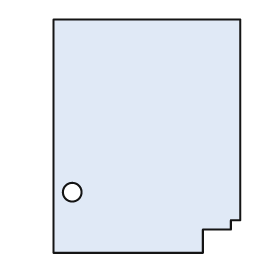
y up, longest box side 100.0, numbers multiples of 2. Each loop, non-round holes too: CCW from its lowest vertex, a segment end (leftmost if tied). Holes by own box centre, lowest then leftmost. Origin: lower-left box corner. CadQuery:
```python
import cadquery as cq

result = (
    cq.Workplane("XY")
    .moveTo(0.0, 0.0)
    .lineTo(64.0, 0.0)
    .lineTo(64.0, 10.0)
    .lineTo(76.0, 10.0)
    .lineTo(76.0, 14.0)
    .lineTo(80.0, 14.0)
    .lineTo(80.0, 100.0)
    .lineTo(0.0, 100.0)
    .close()
    .moveTo(8.0, 26.0)
    .circle(4.0)
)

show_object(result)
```